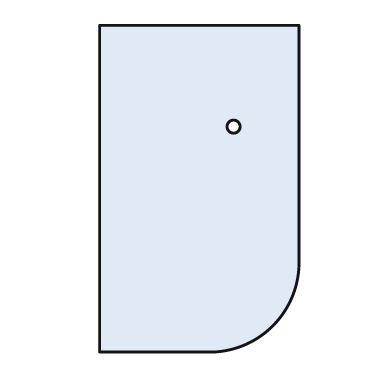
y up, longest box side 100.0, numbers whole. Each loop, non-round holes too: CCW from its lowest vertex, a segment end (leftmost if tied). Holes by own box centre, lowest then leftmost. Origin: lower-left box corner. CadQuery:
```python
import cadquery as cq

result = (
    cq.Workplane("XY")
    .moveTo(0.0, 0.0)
    .lineTo(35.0, 0.0)
    .threePointArc((53.0, 8.0), (61.0, 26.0))
    .lineTo(61.0, 100.0)
    .lineTo(0.0, 100.0)
    .close()
    .moveTo(41.0, 69.0)
    .circle(2.0)
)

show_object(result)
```